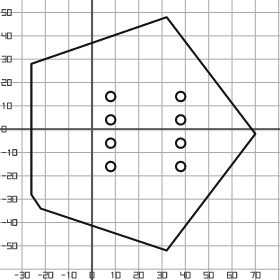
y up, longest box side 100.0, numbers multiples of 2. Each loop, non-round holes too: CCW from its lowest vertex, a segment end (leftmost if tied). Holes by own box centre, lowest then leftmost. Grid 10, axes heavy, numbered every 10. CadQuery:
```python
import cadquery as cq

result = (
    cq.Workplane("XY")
    .moveTo(32.0, -52.0)
    .lineTo(70.0, -2.0)
    .lineTo(32.0, 48.0)
    .lineTo(-26.0, 28.0)
    .lineTo(-26.0, -28.0)
    .lineTo(-22.0, -34.0)
    .close()
    .moveTo(8.0, -16.0)
    .circle(2.0)
    .moveTo(38.0, -16.0)
    .circle(2.0)
    .moveTo(8.0, -6.0)
    .circle(2.0)
    .moveTo(38.0, -6.0)
    .circle(2.0)
    .moveTo(8.0, 4.0)
    .circle(2.0)
    .moveTo(38.0, 4.0)
    .circle(2.0)
    .moveTo(8.0, 14.0)
    .circle(2.0)
    .moveTo(38.0, 14.0)
    .circle(2.0)
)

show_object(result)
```